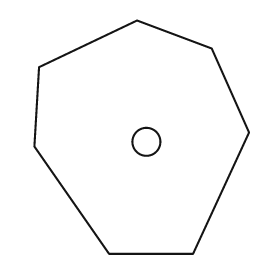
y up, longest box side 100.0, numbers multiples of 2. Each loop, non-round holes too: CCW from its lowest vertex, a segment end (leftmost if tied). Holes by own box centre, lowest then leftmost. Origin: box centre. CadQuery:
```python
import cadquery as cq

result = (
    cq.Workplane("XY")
    .moveTo(-14.0, -50.0)
    .lineTo(22.0, -50.0)
    .lineTo(46.0, 2.0)
    .lineTo(30.0, 38.0)
    .lineTo(-2.0, 50.0)
    .lineTo(-44.0, 30.0)
    .lineTo(-46.0, -4.0)
    .close()
    .moveTo(2.0, -2.0)
    .circle(6.0)
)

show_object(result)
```